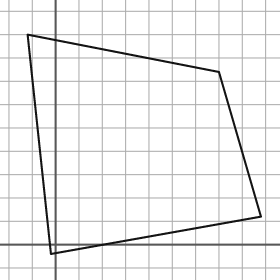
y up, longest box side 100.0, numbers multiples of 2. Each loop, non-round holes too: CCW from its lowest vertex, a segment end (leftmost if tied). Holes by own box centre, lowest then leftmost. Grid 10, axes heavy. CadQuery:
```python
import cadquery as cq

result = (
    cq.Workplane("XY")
    .moveTo(-2.0, -4.0)
    .lineTo(88.0, 12.0)
    .lineTo(70.0, 74.0)
    .lineTo(-12.0, 90.0)
    .close()
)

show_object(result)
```